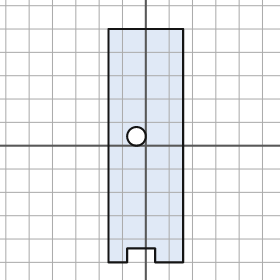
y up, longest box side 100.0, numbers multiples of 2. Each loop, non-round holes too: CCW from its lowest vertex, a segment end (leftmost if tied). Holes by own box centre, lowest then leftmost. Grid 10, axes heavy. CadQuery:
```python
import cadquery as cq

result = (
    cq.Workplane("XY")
    .moveTo(-16.0, -50.0)
    .lineTo(-8.0, -50.0)
    .lineTo(-8.0, -44.0)
    .lineTo(4.0, -44.0)
    .lineTo(4.0, -50.0)
    .lineTo(16.0, -50.0)
    .lineTo(16.0, 50.0)
    .lineTo(-16.0, 50.0)
    .close()
    .moveTo(-4.0, 4.0)
    .circle(4.0)
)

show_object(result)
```